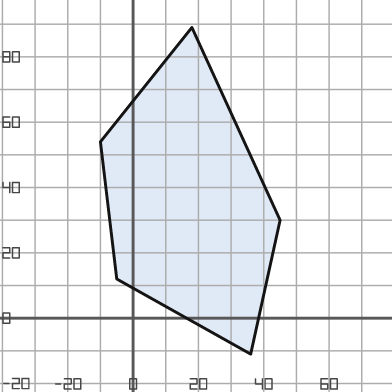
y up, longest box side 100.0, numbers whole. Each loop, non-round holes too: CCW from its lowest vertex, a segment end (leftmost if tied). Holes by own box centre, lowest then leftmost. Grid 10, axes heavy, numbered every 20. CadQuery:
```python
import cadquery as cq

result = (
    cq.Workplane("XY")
    .moveTo(36.0, -11.0)
    .lineTo(45.0, 30.0)
    .lineTo(18.0, 89.0)
    .lineTo(-10.0, 54.0)
    .lineTo(-5.0, 12.0)
    .close()
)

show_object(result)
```